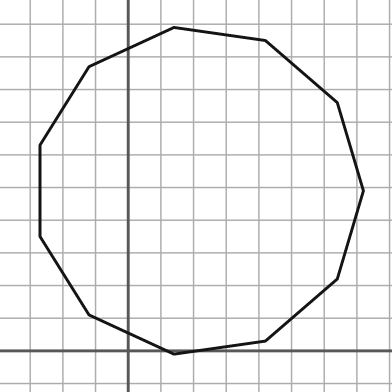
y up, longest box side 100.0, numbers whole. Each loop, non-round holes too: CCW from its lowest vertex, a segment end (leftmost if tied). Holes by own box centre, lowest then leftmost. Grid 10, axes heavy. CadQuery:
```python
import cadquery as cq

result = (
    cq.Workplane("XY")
    .moveTo(14.0, -1.0)
    .lineTo(42.0, 3.0)
    .lineTo(64.0, 22.0)
    .lineTo(72.0, 49.0)
    .lineTo(64.0, 76.0)
    .lineTo(42.0, 95.0)
    .lineTo(14.0, 99.0)
    .lineTo(-12.0, 87.0)
    .lineTo(-27.0, 63.0)
    .lineTo(-27.0, 35.0)
    .lineTo(-12.0, 11.0)
    .close()
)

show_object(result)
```